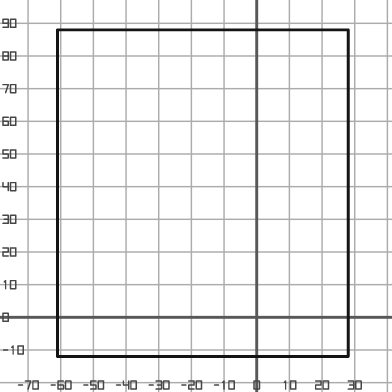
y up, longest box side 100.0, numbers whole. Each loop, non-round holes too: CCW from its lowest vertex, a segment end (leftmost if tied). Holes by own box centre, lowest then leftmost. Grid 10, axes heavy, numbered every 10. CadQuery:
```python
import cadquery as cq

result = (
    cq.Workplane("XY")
    .moveTo(-61.0, -12.0)
    .lineTo(28.0, -12.0)
    .lineTo(28.0, 88.0)
    .lineTo(-61.0, 88.0)
    .close()
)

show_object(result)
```